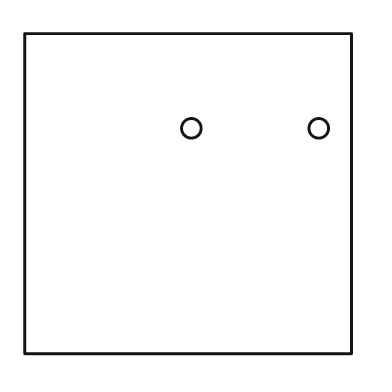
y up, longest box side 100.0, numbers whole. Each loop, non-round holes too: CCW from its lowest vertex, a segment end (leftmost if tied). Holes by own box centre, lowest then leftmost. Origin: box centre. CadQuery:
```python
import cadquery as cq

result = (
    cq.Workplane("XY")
    .moveTo(-50.0, -49.0)
    .lineTo(50.0, -49.0)
    .lineTo(50.0, 49.0)
    .lineTo(-50.0, 49.0)
    .close()
    .moveTo(1.0, 20.0)
    .circle(3.0)
    .moveTo(40.0, 20.0)
    .circle(3.0)
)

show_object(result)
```